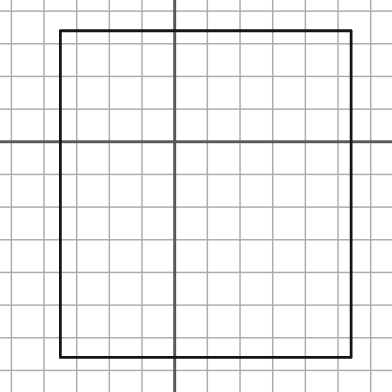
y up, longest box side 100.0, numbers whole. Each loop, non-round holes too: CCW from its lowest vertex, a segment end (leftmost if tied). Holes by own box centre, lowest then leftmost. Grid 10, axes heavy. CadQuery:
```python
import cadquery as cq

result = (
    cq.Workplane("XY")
    .moveTo(-35.0, -66.0)
    .lineTo(54.0, -66.0)
    .lineTo(54.0, 34.0)
    .lineTo(-35.0, 34.0)
    .close()
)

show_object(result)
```